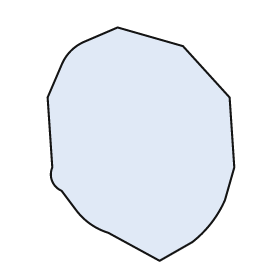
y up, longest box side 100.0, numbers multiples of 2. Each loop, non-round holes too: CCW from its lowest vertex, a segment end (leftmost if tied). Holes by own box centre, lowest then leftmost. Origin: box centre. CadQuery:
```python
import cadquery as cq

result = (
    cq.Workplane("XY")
    .moveTo(8.0, -50.0)
    .lineTo(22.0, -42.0)
    .threePointArc((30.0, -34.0), (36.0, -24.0))
    .lineTo(40.0, -10.0)
    .lineTo(38.0, 20.0)
    .lineTo(18.0, 42.0)
    .lineTo(-10.0, 50.0)
    .lineTo(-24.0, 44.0)
    .threePointArc((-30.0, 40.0), (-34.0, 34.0))
    .lineTo(-40.0, 20.0)
    .lineTo(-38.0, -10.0)
    .threePointArc((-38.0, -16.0), (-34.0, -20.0))
    .lineTo(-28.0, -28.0)
    .threePointArc((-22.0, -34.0), (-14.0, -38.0))
    .close()
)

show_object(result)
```